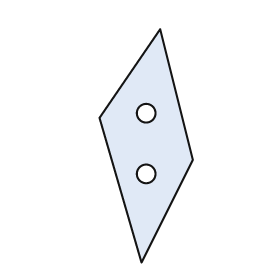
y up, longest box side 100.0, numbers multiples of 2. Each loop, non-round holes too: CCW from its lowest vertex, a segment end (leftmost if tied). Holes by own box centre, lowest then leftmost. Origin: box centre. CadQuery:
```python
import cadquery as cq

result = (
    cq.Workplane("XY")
    .moveTo(-2.0, -50.0)
    .lineTo(20.0, -6.0)
    .lineTo(6.0, 50.0)
    .lineTo(-20.0, 12.0)
    .close()
    .moveTo(0.0, -12.0)
    .circle(4.0)
    .moveTo(0.0, 14.0)
    .circle(4.0)
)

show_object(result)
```